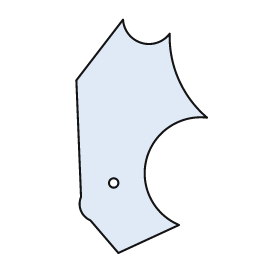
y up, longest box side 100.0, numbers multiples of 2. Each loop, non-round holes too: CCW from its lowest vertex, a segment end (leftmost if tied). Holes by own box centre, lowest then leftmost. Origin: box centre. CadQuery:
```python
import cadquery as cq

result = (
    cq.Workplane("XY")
    .moveTo(-10.0, -50.0)
    .lineTo(16.0, -38.0)
    .threePointArc((2.0, -10.0), (28.0, 8.0))
    .threePointArc((16.0, 24.0), (12.0, 44.0))
    .threePointArc((0.0, 40.0), (-8.0, 50.0))
    .lineTo(-28.0, 24.0)
    .lineTo(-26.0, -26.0)
    .threePointArc((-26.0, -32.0), (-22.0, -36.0))
    .close()
    .moveTo(-12.0, -20.0)
    .circle(2.0)
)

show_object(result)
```